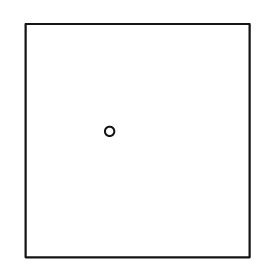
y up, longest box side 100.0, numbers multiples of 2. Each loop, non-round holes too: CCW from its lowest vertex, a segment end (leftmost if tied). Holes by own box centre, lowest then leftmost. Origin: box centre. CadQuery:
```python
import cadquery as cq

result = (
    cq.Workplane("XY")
    .moveTo(-48.0, -50.0)
    .lineTo(48.0, -50.0)
    .lineTo(48.0, 50.0)
    .lineTo(-48.0, 50.0)
    .close()
    .moveTo(-12.0, 4.0)
    .circle(2.0)
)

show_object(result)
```